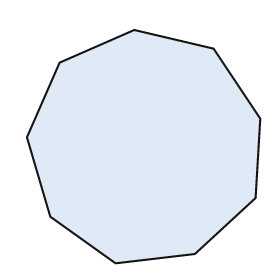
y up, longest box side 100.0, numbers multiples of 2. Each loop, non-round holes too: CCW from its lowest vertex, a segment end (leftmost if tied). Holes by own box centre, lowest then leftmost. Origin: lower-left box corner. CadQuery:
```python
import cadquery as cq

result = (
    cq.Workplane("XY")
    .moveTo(38.0, 0.0)
    .lineTo(72.0, 4.0)
    .lineTo(98.0, 28.0)
    .lineTo(100.0, 62.0)
    .lineTo(80.0, 92.0)
    .lineTo(46.0, 100.0)
    .lineTo(14.0, 86.0)
    .lineTo(0.0, 54.0)
    .lineTo(10.0, 20.0)
    .close()
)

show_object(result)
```